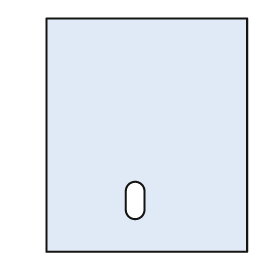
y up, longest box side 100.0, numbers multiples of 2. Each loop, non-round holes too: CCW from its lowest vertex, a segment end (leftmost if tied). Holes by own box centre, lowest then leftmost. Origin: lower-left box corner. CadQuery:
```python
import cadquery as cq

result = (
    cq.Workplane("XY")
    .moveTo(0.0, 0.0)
    .lineTo(86.0, 0.0)
    .lineTo(86.0, 100.0)
    .lineTo(0.0, 100.0)
    .close()
    .moveTo(34.0, 18.0)
    .threePointArc((38.0, 14.0), (42.0, 18.0))
    .lineTo(42.0, 26.0)
    .threePointArc((38.0, 30.0), (34.0, 26.0))
    .close()
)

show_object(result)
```